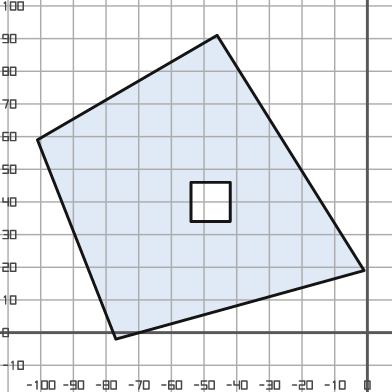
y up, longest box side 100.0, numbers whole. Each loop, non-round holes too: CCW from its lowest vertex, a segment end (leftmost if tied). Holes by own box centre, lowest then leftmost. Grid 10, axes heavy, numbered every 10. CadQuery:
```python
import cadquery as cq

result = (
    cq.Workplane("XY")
    .moveTo(-77.0, -2.0)
    .lineTo(-1.0, 19.0)
    .lineTo(-46.0, 91.0)
    .lineTo(-101.0, 59.0)
    .close()
    .moveTo(-54.0, 34.0)
    .lineTo(-42.0, 34.0)
    .lineTo(-42.0, 46.0)
    .lineTo(-54.0, 46.0)
    .close()
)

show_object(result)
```